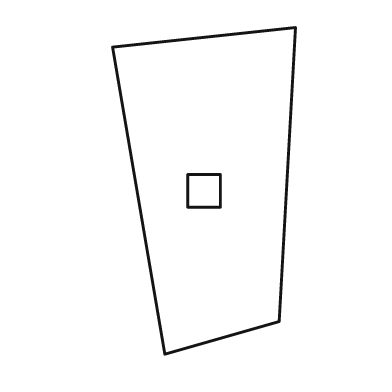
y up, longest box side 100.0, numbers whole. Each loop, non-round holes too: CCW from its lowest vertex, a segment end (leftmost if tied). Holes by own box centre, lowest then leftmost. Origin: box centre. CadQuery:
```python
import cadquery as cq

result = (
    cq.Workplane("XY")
    .moveTo(-12.0, -50.0)
    .lineTo(23.0, -40.0)
    .lineTo(28.0, 50.0)
    .lineTo(-28.0, 44.0)
    .close()
    .moveTo(-5.0, -5.0)
    .lineTo(5.0, -5.0)
    .lineTo(5.0, 5.0)
    .lineTo(-5.0, 5.0)
    .close()
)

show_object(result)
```